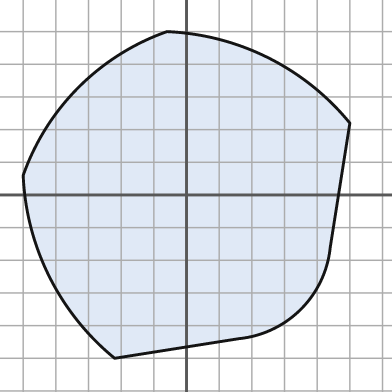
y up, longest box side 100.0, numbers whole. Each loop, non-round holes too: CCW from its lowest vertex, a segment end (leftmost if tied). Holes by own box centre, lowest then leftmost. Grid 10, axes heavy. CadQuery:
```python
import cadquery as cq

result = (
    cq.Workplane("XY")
    .moveTo(-22.0, -50.0)
    .lineTo(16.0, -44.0)
    .threePointArc((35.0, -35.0), (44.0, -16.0))
    .lineTo(50.0, 22.0)
    .threePointArc((25.0, 42.0), (-6.0, 50.0))
    .threePointArc((-33.0, 33.0), (-50.0, 6.0))
    .threePointArc((-42.0, -25.0), (-22.0, -50.0))
    .close()
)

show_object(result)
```